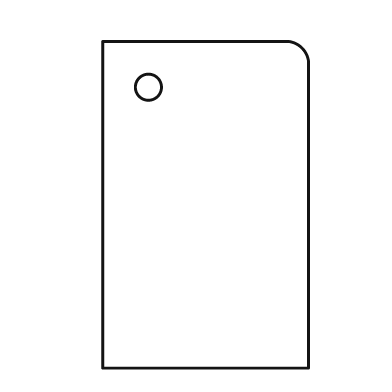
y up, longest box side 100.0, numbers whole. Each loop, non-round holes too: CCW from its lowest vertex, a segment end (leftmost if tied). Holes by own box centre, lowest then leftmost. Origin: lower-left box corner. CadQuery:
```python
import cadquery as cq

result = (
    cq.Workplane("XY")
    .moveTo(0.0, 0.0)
    .lineTo(63.0, 0.0)
    .lineTo(63.0, 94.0)
    .threePointArc((61.0, 98.0), (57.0, 100.0))
    .lineTo(0.0, 100.0)
    .close()
    .moveTo(14.0, 86.0)
    .circle(4.0)
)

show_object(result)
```